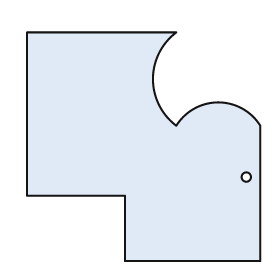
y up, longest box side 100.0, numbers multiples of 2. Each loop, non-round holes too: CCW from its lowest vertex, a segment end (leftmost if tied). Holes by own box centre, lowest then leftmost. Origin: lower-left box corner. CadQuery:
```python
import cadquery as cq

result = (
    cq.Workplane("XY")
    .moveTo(42.0, 0.0)
    .lineTo(100.0, 0.0)
    .lineTo(100.0, 58.0)
    .threePointArc((82.0, 68.0), (64.0, 58.0))
    .threePointArc((54.0, 78.0), (64.0, 98.0))
    .lineTo(0.0, 98.0)
    .lineTo(0.0, 28.0)
    .lineTo(42.0, 28.0)
    .close()
    .moveTo(94.0, 36.0)
    .circle(2.0)
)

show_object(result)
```